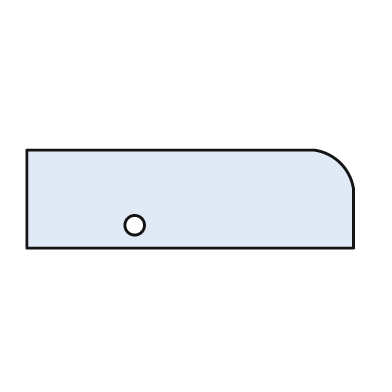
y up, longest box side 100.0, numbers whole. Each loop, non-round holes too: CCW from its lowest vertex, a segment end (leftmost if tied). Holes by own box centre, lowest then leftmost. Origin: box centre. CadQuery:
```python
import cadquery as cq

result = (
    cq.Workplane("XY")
    .moveTo(-50.0, -15.0)
    .lineTo(50.0, -15.0)
    .lineTo(50.0, 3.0)
    .threePointArc((46.0, 11.0), (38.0, 15.0))
    .lineTo(-50.0, 15.0)
    .close()
    .moveTo(-17.0, -8.0)
    .circle(3.0)
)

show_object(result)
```